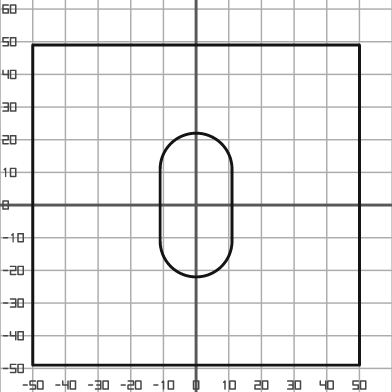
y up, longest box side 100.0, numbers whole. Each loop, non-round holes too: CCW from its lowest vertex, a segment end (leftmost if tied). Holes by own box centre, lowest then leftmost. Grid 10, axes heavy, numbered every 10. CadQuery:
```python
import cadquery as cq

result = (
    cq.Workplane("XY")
    .moveTo(-50.0, -49.0)
    .lineTo(50.0, -49.0)
    .lineTo(50.0, 49.0)
    .lineTo(-50.0, 49.0)
    .close()
    .moveTo(-11.0, -11.0)
    .threePointArc((0.0, -22.0), (11.0, -11.0))
    .lineTo(11.0, 11.0)
    .threePointArc((0.0, 22.0), (-11.0, 11.0))
    .close()
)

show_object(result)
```